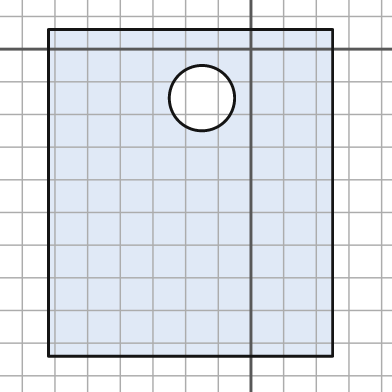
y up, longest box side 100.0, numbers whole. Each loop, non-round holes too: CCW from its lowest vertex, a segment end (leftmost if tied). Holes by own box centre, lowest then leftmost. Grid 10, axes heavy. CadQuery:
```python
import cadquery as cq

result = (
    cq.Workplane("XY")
    .moveTo(-62.0, -94.0)
    .lineTo(25.0, -94.0)
    .lineTo(25.0, 6.0)
    .lineTo(-62.0, 6.0)
    .close()
    .moveTo(-15.0, -15.0)
    .circle(10.0)
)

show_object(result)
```